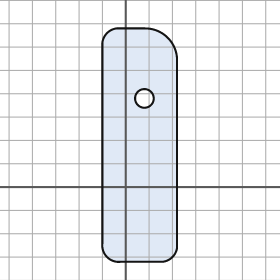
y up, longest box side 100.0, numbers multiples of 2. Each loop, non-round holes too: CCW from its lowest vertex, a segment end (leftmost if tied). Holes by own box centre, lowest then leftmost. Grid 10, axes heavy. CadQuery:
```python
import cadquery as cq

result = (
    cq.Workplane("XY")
    .moveTo(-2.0, -32.0)
    .lineTo(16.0, -32.0)
    .threePointArc((20.0, -30.0), (22.0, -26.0))
    .lineTo(22.0, 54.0)
    .threePointArc((18.0, 64.0), (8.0, 68.0))
    .lineTo(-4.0, 68.0)
    .threePointArc((-8.0, 66.0), (-10.0, 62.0))
    .lineTo(-10.0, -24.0)
    .threePointArc((-8.0, -30.0), (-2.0, -32.0))
    .close()
    .moveTo(8.0, 38.0)
    .circle(4.0)
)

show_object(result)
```